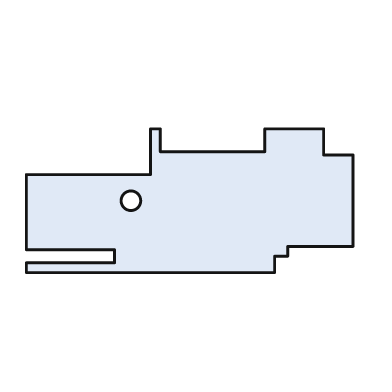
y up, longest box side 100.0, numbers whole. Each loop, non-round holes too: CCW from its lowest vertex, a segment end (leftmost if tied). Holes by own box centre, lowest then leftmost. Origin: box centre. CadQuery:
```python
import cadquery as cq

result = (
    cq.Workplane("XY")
    .moveTo(-50.0, -22.0)
    .lineTo(26.0, -22.0)
    .lineTo(26.0, -17.0)
    .lineTo(30.0, -17.0)
    .lineTo(30.0, -14.0)
    .lineTo(50.0, -14.0)
    .lineTo(50.0, 14.0)
    .lineTo(41.0, 14.0)
    .lineTo(41.0, 22.0)
    .lineTo(23.0, 22.0)
    .lineTo(23.0, 15.0)
    .lineTo(-9.0, 15.0)
    .lineTo(-9.0, 22.0)
    .lineTo(-12.0, 22.0)
    .lineTo(-12.0, 8.0)
    .lineTo(-50.0, 8.0)
    .lineTo(-50.0, -15.0)
    .lineTo(-23.0, -15.0)
    .lineTo(-23.0, -19.0)
    .lineTo(-50.0, -19.0)
    .close()
    .moveTo(-18.0, 0.0)
    .circle(3.0)
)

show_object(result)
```